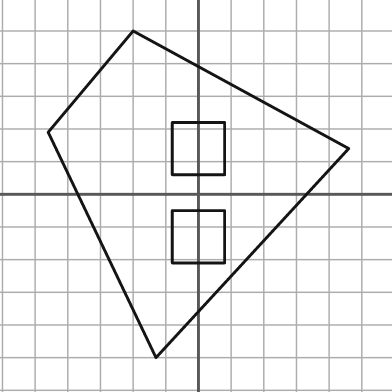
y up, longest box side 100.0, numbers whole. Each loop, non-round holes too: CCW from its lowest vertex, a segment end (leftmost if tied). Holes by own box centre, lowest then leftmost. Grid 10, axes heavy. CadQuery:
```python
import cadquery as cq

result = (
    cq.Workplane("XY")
    .moveTo(-13.0, -50.0)
    .lineTo(46.0, 14.0)
    .lineTo(-20.0, 50.0)
    .lineTo(-46.0, 19.0)
    .close()
    .moveTo(-8.0, -21.0)
    .lineTo(8.0, -21.0)
    .lineTo(8.0, -5.0)
    .lineTo(-8.0, -5.0)
    .close()
    .moveTo(-8.0, 6.0)
    .lineTo(8.0, 6.0)
    .lineTo(8.0, 22.0)
    .lineTo(-8.0, 22.0)
    .close()
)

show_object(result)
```